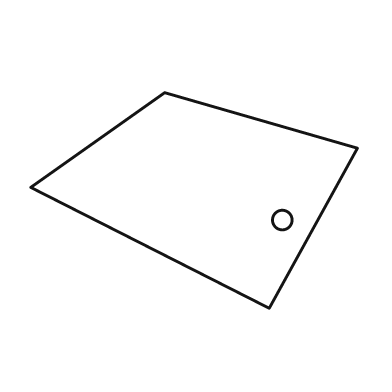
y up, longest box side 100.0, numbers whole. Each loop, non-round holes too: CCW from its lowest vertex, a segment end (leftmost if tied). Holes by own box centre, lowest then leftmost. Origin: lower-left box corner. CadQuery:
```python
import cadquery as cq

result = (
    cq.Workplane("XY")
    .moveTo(73.0, 0.0)
    .lineTo(100.0, 49.0)
    .lineTo(41.0, 66.0)
    .lineTo(0.0, 37.0)
    .close()
    .moveTo(77.0, 27.0)
    .circle(3.0)
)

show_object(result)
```